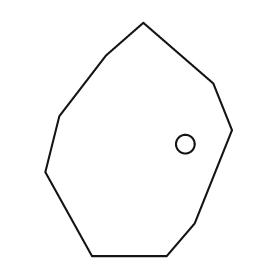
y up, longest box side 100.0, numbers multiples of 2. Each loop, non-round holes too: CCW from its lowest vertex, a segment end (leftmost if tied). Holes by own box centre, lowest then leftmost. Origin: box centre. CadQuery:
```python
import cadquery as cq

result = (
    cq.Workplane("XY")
    .moveTo(-20.0, -50.0)
    .lineTo(12.0, -50.0)
    .lineTo(24.0, -36.0)
    .lineTo(40.0, 4.0)
    .lineTo(32.0, 24.0)
    .lineTo(2.0, 50.0)
    .lineTo(-14.0, 36.0)
    .lineTo(-34.0, 10.0)
    .lineTo(-40.0, -14.0)
    .close()
    .moveTo(20.0, -2.0)
    .circle(4.0)
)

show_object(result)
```